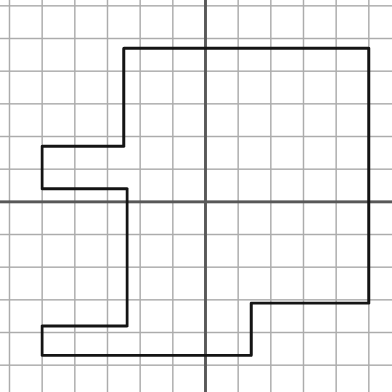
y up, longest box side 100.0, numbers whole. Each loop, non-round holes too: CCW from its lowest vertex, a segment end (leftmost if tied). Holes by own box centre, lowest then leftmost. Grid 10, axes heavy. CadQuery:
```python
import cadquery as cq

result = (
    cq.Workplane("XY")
    .moveTo(-50.0, -47.0)
    .lineTo(14.0, -47.0)
    .lineTo(14.0, -31.0)
    .lineTo(50.0, -31.0)
    .lineTo(50.0, 47.0)
    .lineTo(-25.0, 47.0)
    .lineTo(-25.0, 17.0)
    .lineTo(-50.0, 17.0)
    .lineTo(-50.0, 4.0)
    .lineTo(-24.0, 4.0)
    .lineTo(-24.0, -38.0)
    .lineTo(-50.0, -38.0)
    .close()
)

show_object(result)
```